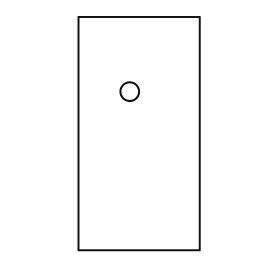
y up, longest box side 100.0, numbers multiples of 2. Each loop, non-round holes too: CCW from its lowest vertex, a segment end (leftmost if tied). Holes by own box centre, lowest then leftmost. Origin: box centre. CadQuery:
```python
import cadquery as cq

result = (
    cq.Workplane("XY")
    .moveTo(-26.0, -50.0)
    .lineTo(26.0, -50.0)
    .lineTo(26.0, 50.0)
    .lineTo(-26.0, 50.0)
    .close()
    .moveTo(-4.0, 18.0)
    .circle(4.0)
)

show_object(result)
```